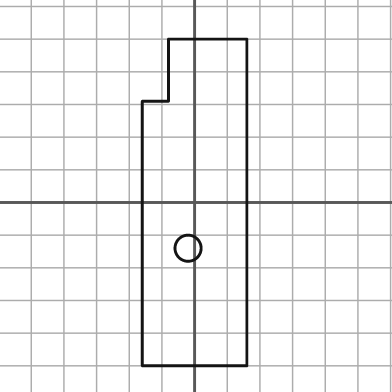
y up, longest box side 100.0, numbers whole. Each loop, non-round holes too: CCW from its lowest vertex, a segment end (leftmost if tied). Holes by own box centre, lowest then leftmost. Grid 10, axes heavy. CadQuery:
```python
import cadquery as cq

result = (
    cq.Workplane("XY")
    .moveTo(-16.0, -50.0)
    .lineTo(16.0, -50.0)
    .lineTo(16.0, 50.0)
    .lineTo(-8.0, 50.0)
    .lineTo(-8.0, 31.0)
    .lineTo(-16.0, 31.0)
    .close()
    .moveTo(-2.0, -14.0)
    .circle(4.0)
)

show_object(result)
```